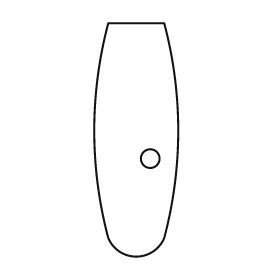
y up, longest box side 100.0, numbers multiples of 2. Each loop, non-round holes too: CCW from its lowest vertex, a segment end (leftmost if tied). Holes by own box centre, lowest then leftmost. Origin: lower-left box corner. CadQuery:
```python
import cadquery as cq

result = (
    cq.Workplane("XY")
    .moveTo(6.0, 8.0)
    .threePointArc((18.0, 0.0), (30.0, 8.0))
    .threePointArc((36.0, 54.0), (30.0, 100.0))
    .lineTo(6.0, 100.0)
    .threePointArc((0.0, 54.0), (6.0, 8.0))
    .close()
    .moveTo(24.0, 42.0)
    .circle(4.0)
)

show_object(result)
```